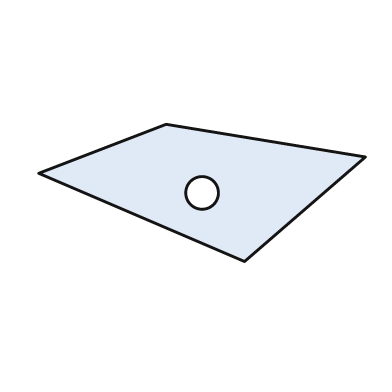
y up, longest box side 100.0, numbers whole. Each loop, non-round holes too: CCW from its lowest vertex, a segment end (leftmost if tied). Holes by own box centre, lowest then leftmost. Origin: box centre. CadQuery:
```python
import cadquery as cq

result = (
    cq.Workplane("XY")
    .moveTo(13.0, -21.0)
    .lineTo(50.0, 11.0)
    .lineTo(-11.0, 21.0)
    .lineTo(-50.0, 6.0)
    .close()
    .moveTo(0.0, 0.0)
    .circle(5.0)
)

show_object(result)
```